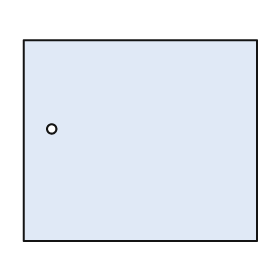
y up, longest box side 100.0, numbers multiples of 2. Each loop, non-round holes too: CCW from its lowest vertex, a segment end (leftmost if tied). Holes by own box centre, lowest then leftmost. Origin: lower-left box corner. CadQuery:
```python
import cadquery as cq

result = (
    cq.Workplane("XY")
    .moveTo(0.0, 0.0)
    .lineTo(100.0, 0.0)
    .lineTo(100.0, 86.0)
    .lineTo(0.0, 86.0)
    .close()
    .moveTo(12.0, 48.0)
    .circle(2.0)
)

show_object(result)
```